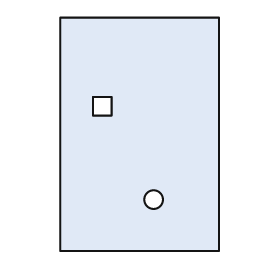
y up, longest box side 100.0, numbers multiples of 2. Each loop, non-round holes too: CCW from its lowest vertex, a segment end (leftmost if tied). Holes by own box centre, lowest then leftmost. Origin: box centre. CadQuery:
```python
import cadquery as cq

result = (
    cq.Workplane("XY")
    .moveTo(-34.0, -50.0)
    .lineTo(34.0, -50.0)
    .lineTo(34.0, 50.0)
    .lineTo(-34.0, 50.0)
    .close()
    .moveTo(6.0, -28.0)
    .circle(4.0)
    .moveTo(-20.0, 8.0)
    .lineTo(-12.0, 8.0)
    .lineTo(-12.0, 16.0)
    .lineTo(-20.0, 16.0)
    .close()
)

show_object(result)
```